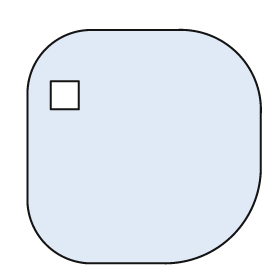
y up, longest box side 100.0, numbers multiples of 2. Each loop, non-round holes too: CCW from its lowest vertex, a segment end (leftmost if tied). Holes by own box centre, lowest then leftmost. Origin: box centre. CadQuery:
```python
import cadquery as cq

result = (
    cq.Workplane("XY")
    .moveTo(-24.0, -50.0)
    .lineTo(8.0, -50.0)
    .threePointArc((38.0, -38.0), (50.0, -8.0))
    .lineTo(50.0, 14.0)
    .threePointArc((40.0, 40.0), (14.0, 50.0))
    .lineTo(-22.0, 50.0)
    .threePointArc((-42.0, 42.0), (-50.0, 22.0))
    .lineTo(-50.0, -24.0)
    .threePointArc((-42.0, -42.0), (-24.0, -50.0))
    .close()
    .moveTo(-40.0, 16.0)
    .lineTo(-28.0, 16.0)
    .lineTo(-28.0, 28.0)
    .lineTo(-40.0, 28.0)
    .close()
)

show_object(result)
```